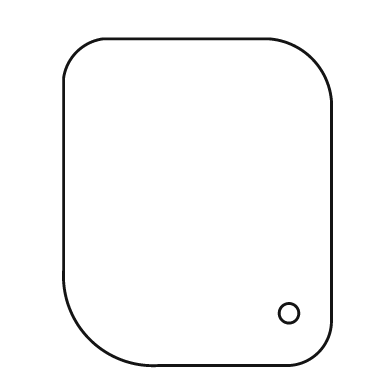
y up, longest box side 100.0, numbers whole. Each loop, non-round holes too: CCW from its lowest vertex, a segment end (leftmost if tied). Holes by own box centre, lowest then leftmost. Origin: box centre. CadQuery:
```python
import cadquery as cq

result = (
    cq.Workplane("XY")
    .moveTo(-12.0, -50.0)
    .lineTo(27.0, -50.0)
    .threePointArc((37.0, -46.0), (41.0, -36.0))
    .lineTo(41.0, 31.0)
    .threePointArc((35.0, 44.0), (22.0, 50.0))
    .lineTo(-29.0, 50.0)
    .threePointArc((-37.0, 46.0), (-41.0, 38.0))
    .lineTo(-41.0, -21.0)
    .threePointArc((-33.0, -42.0), (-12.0, -50.0))
    .close()
    .moveTo(28.0, -34.0)
    .circle(3.0)
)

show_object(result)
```